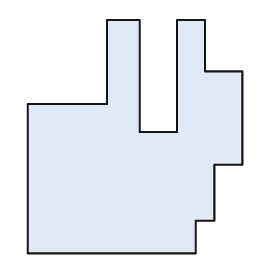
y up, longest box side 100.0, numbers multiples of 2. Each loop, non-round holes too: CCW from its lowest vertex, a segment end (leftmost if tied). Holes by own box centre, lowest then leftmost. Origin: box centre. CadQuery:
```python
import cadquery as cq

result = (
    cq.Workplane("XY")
    .moveTo(-46.0, -50.0)
    .lineTo(26.0, -50.0)
    .lineTo(26.0, -36.0)
    .lineTo(34.0, -36.0)
    .lineTo(34.0, -12.0)
    .lineTo(46.0, -12.0)
    .lineTo(46.0, 28.0)
    .lineTo(30.0, 28.0)
    .lineTo(30.0, 50.0)
    .lineTo(18.0, 50.0)
    .lineTo(18.0, 2.0)
    .lineTo(2.0, 2.0)
    .lineTo(2.0, 50.0)
    .lineTo(-12.0, 50.0)
    .lineTo(-12.0, 14.0)
    .lineTo(-46.0, 14.0)
    .close()
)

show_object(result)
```